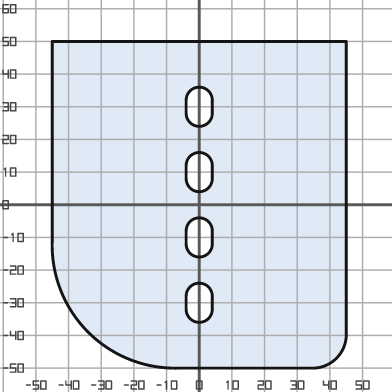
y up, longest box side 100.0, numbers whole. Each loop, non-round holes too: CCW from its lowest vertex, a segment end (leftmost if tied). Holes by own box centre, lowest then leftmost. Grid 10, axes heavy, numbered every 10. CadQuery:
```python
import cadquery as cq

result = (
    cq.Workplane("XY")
    .moveTo(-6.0, -50.0)
    .lineTo(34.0, -50.0)
    .threePointArc((42.0, -47.0), (45.0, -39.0))
    .lineTo(45.0, 50.0)
    .lineTo(-45.0, 50.0)
    .lineTo(-45.0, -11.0)
    .threePointArc((-34.0, -39.0), (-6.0, -50.0))
    .close()
    .moveTo(-4.0, -32.0)
    .threePointArc((0.0, -36.0), (4.0, -32.0))
    .lineTo(4.0, -28.0)
    .threePointArc((0.0, -24.0), (-4.0, -28.0))
    .close()
    .moveTo(-4.0, -12.0)
    .threePointArc((0.0, -16.0), (4.0, -12.0))
    .lineTo(4.0, -8.0)
    .threePointArc((0.0, -4.0), (-4.0, -8.0))
    .close()
    .moveTo(-4.0, 8.0)
    .threePointArc((0.0, 4.0), (4.0, 8.0))
    .lineTo(4.0, 12.0)
    .threePointArc((0.0, 16.0), (-4.0, 12.0))
    .close()
    .moveTo(-4.0, 28.0)
    .threePointArc((0.0, 24.0), (4.0, 28.0))
    .lineTo(4.0, 32.0)
    .threePointArc((0.0, 36.0), (-4.0, 32.0))
    .close()
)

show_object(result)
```